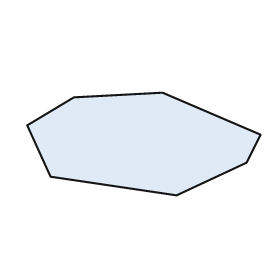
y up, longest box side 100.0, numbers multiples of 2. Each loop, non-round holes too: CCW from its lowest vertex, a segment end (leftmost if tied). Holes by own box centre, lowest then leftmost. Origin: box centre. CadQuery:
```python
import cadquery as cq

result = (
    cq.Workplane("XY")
    .moveTo(14.0, -22.0)
    .lineTo(44.0, -8.0)
    .lineTo(50.0, 4.0)
    .lineTo(8.0, 22.0)
    .lineTo(-30.0, 20.0)
    .lineTo(-50.0, 8.0)
    .lineTo(-40.0, -14.0)
    .close()
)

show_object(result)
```